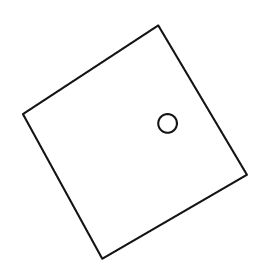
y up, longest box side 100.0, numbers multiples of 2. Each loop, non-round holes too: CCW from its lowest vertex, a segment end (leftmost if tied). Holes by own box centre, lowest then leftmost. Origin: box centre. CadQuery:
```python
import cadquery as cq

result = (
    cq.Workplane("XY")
    .moveTo(-14.0, -50.0)
    .lineTo(48.0, -14.0)
    .lineTo(10.0, 50.0)
    .lineTo(-48.0, 12.0)
    .close()
    .moveTo(14.0, 8.0)
    .circle(4.0)
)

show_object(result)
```